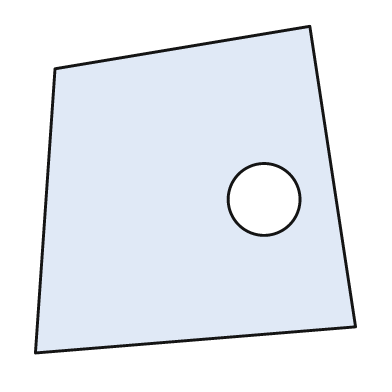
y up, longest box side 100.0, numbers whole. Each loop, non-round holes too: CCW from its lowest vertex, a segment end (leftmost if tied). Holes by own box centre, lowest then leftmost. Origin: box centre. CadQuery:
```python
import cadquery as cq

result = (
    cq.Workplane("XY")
    .moveTo(-49.0, -50.0)
    .lineTo(49.0, -42.0)
    .lineTo(35.0, 50.0)
    .lineTo(-43.0, 37.0)
    .close()
    .moveTo(21.0, -3.0)
    .circle(11.0)
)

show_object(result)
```